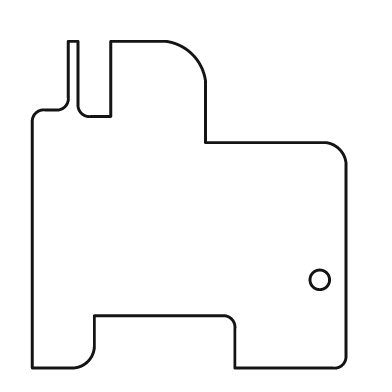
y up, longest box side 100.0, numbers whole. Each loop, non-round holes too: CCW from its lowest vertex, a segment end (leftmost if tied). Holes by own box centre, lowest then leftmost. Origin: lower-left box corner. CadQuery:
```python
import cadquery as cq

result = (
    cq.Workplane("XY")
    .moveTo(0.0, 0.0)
    .lineTo(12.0, 0.0)
    .threePointArc((17.0, 2.0), (19.0, 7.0))
    .lineTo(19.0, 16.0)
    .lineTo(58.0, 16.0)
    .threePointArc((61.0, 15.0), (62.0, 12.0))
    .lineTo(62.0, 0.0)
    .lineTo(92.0, 0.0)
    .threePointArc((95.0, 1.0), (96.0, 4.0))
    .lineTo(96.0, 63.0)
    .threePointArc((94.0, 67.0), (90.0, 69.0))
    .lineTo(53.0, 69.0)
    .lineTo(53.0, 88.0)
    .threePointArc((49.0, 96.0), (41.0, 100.0))
    .lineTo(24.0, 100.0)
    .lineTo(24.0, 77.0)
    .lineTo(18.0, 77.0)
    .threePointArc((15.0, 78.0), (14.0, 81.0))
    .lineTo(14.0, 100.0)
    .lineTo(11.0, 100.0)
    .lineTo(11.0, 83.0)
    .threePointArc((10.0, 80.0), (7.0, 79.0))
    .lineTo(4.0, 79.0)
    .threePointArc((1.0, 78.0), (0.0, 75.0))
    .close()
    .moveTo(88.0, 27.0)
    .circle(3.0)
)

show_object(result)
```